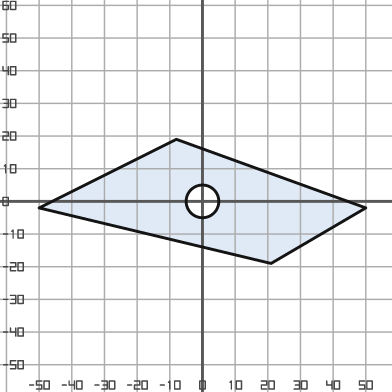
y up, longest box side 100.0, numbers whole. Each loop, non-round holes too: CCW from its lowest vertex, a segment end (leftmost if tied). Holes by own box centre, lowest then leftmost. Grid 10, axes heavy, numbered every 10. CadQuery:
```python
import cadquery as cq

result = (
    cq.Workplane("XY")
    .moveTo(21.0, -19.0)
    .lineTo(50.0, -2.0)
    .lineTo(-8.0, 19.0)
    .lineTo(-50.0, -2.0)
    .close()
    .moveTo(0.0, 0.0)
    .circle(5.0)
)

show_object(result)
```